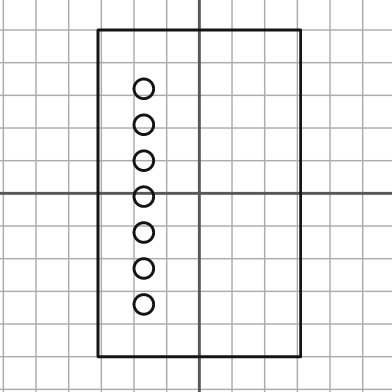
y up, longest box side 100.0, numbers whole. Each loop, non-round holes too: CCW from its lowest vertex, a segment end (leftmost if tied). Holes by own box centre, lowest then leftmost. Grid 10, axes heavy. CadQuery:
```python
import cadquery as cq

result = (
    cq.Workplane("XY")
    .moveTo(-31.0, -50.0)
    .lineTo(31.0, -50.0)
    .lineTo(31.0, 50.0)
    .lineTo(-31.0, 50.0)
    .close()
    .moveTo(-17.0, -34.0)
    .circle(3.0)
    .moveTo(-17.0, -23.0)
    .circle(3.0)
    .moveTo(-17.0, -12.0)
    .circle(3.0)
    .moveTo(-17.0, -1.0)
    .circle(3.0)
    .moveTo(-17.0, 10.0)
    .circle(3.0)
    .moveTo(-17.0, 21.0)
    .circle(3.0)
    .moveTo(-17.0, 32.0)
    .circle(3.0)
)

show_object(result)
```